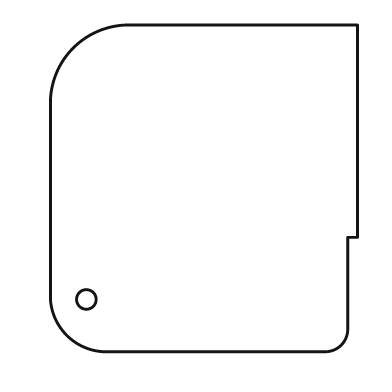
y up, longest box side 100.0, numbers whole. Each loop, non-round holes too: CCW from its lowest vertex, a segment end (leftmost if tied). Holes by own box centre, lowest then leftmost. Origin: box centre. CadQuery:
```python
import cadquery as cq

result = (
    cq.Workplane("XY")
    .moveTo(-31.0, -50.0)
    .lineTo(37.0, -50.0)
    .threePointArc((42.0, -48.0), (44.0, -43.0))
    .lineTo(44.0, -15.0)
    .lineTo(47.0, -15.0)
    .lineTo(47.0, 50.0)
    .lineTo(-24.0, 50.0)
    .threePointArc((-40.0, 43.0), (-47.0, 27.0))
    .lineTo(-47.0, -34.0)
    .threePointArc((-42.0, -45.0), (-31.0, -50.0))
    .close()
    .moveTo(-36.0, -34.0)
    .circle(3.0)
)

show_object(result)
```